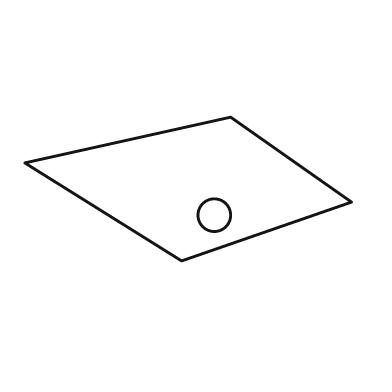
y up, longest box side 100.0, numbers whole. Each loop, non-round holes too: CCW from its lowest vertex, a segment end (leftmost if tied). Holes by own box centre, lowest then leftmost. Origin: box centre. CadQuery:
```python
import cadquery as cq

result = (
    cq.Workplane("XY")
    .moveTo(-2.0, -22.0)
    .lineTo(50.0, -4.0)
    .lineTo(13.0, 22.0)
    .lineTo(-50.0, 8.0)
    .close()
    .moveTo(8.0, -8.0)
    .circle(5.0)
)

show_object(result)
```